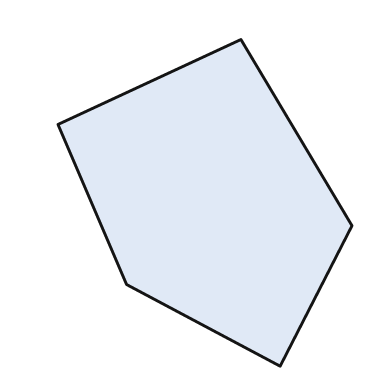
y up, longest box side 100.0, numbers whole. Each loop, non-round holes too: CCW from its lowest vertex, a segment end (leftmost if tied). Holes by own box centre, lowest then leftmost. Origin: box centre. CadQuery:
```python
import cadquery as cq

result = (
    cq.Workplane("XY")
    .moveTo(23.0, -50.0)
    .lineTo(45.0, -7.0)
    .lineTo(11.0, 50.0)
    .lineTo(-45.0, 24.0)
    .lineTo(-24.0, -25.0)
    .close()
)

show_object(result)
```